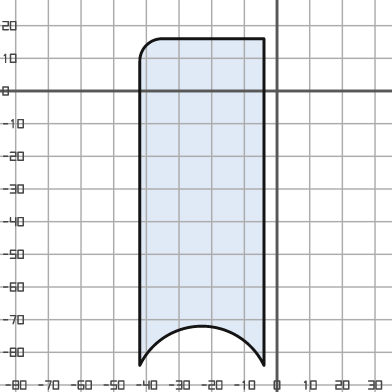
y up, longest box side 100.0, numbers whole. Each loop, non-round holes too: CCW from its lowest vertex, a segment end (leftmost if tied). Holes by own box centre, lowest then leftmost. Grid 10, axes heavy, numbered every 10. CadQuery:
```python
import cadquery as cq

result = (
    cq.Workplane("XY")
    .moveTo(-42.0, -84.0)
    .threePointArc((-23.0, -72.0), (-4.0, -84.0))
    .lineTo(-4.0, 16.0)
    .lineTo(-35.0, 16.0)
    .threePointArc((-40.0, 14.0), (-42.0, 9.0))
    .close()
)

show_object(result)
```